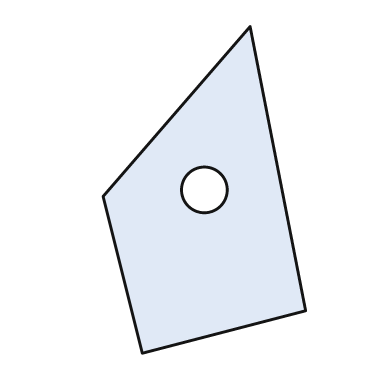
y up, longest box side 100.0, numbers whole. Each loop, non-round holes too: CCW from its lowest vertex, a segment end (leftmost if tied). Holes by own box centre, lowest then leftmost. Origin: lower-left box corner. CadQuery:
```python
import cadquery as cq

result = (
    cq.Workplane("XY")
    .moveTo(12.0, 0.0)
    .lineTo(62.0, 13.0)
    .lineTo(45.0, 100.0)
    .lineTo(0.0, 48.0)
    .close()
    .moveTo(31.0, 50.0)
    .circle(7.0)
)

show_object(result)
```